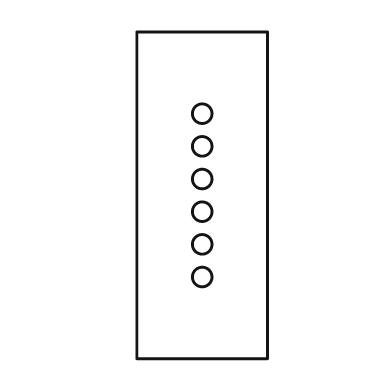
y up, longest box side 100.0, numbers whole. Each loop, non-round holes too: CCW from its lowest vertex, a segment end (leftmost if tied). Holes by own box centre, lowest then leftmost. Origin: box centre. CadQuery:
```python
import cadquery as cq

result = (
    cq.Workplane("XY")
    .moveTo(-20.0, -50.0)
    .lineTo(20.0, -50.0)
    .lineTo(20.0, 50.0)
    .lineTo(-20.0, 50.0)
    .close()
    .moveTo(0.0, -25.0)
    .circle(3.0)
    .moveTo(0.0, -15.0)
    .circle(3.0)
    .moveTo(0.0, -5.0)
    .circle(3.0)
    .moveTo(0.0, 5.0)
    .circle(3.0)
    .moveTo(0.0, 15.0)
    .circle(3.0)
    .moveTo(0.0, 25.0)
    .circle(3.0)
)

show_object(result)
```